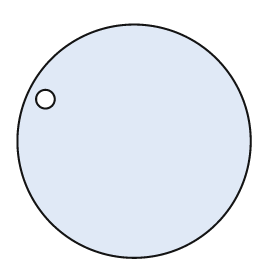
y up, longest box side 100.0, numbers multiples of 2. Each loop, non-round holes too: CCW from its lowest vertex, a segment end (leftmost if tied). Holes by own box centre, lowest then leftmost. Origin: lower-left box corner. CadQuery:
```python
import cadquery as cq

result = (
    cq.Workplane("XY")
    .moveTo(50.0, 50.0)
    .circle(50.0)
    .moveTo(12.0, 68.0)
    .circle(4.0)
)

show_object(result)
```